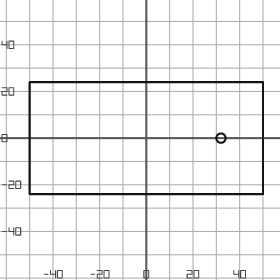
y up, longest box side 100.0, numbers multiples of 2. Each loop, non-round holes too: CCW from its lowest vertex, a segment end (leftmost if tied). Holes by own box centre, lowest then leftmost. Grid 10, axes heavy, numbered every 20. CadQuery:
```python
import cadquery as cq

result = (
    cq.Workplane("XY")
    .moveTo(-50.0, -24.0)
    .lineTo(50.0, -24.0)
    .lineTo(50.0, 24.0)
    .lineTo(-50.0, 24.0)
    .close()
    .moveTo(32.0, 0.0)
    .circle(2.0)
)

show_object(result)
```